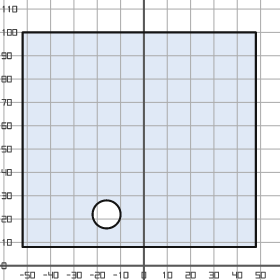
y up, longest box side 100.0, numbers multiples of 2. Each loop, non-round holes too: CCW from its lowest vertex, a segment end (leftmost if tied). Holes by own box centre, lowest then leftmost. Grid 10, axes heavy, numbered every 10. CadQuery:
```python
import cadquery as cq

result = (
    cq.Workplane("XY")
    .moveTo(-52.0, 8.0)
    .lineTo(48.0, 8.0)
    .lineTo(48.0, 100.0)
    .lineTo(-52.0, 100.0)
    .close()
    .moveTo(-16.0, 22.0)
    .circle(6.0)
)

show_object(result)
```